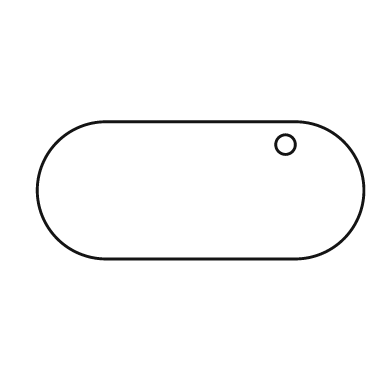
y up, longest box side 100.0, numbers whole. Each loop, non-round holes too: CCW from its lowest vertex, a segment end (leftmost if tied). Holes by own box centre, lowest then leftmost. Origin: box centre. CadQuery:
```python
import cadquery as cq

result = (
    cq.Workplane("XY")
    .moveTo(-29.0, -21.0)
    .lineTo(29.0, -21.0)
    .threePointArc((50.0, 0.0), (29.0, 21.0))
    .lineTo(-29.0, 21.0)
    .threePointArc((-50.0, 0.0), (-29.0, -21.0))
    .close()
    .moveTo(26.0, 14.0)
    .circle(3.0)
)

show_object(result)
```